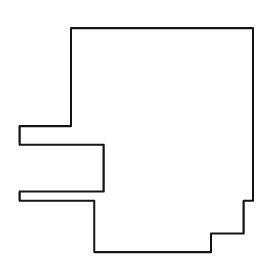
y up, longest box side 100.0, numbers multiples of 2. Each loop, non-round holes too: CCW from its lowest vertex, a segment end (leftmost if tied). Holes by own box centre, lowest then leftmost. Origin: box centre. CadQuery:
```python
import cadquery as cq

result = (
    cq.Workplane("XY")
    .moveTo(-18.0, -48.0)
    .lineTo(32.0, -48.0)
    .lineTo(32.0, -40.0)
    .lineTo(46.0, -40.0)
    .lineTo(46.0, -26.0)
    .lineTo(50.0, -26.0)
    .lineTo(50.0, 48.0)
    .lineTo(-28.0, 48.0)
    .lineTo(-28.0, 6.0)
    .lineTo(-50.0, 6.0)
    .lineTo(-50.0, -2.0)
    .lineTo(-14.0, -2.0)
    .lineTo(-14.0, -22.0)
    .lineTo(-50.0, -22.0)
    .lineTo(-50.0, -26.0)
    .lineTo(-18.0, -26.0)
    .close()
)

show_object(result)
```